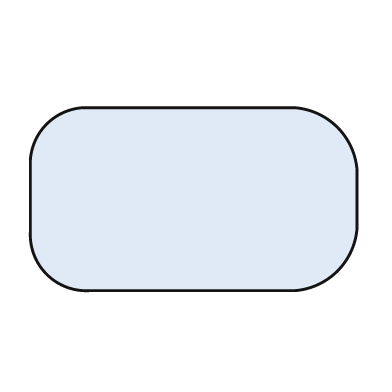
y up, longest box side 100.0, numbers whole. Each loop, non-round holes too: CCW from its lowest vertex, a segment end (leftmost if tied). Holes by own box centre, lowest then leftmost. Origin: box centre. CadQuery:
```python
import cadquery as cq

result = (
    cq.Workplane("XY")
    .moveTo(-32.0, -28.0)
    .lineTo(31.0, -28.0)
    .threePointArc((44.0, -22.0), (50.0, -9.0))
    .lineTo(50.0, 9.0)
    .threePointArc((44.0, 22.0), (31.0, 28.0))
    .lineTo(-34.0, 28.0)
    .threePointArc((-45.0, 23.0), (-50.0, 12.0))
    .lineTo(-50.0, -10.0)
    .threePointArc((-45.0, -23.0), (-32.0, -28.0))
    .close()
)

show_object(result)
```